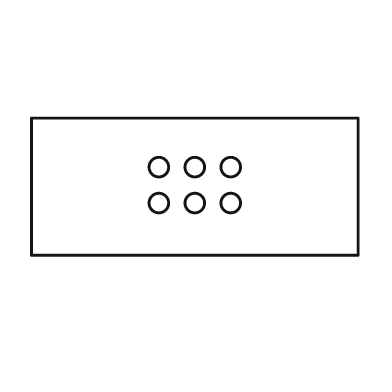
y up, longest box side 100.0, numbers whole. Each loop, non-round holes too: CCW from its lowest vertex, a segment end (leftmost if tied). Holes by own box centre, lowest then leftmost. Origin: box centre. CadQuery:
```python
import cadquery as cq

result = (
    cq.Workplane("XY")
    .moveTo(-50.0, -21.0)
    .lineTo(50.0, -21.0)
    .lineTo(50.0, 21.0)
    .lineTo(-50.0, 21.0)
    .close()
    .moveTo(-11.0, -5.0)
    .circle(3.0)
    .moveTo(0.0, -5.0)
    .circle(3.0)
    .moveTo(11.0, -5.0)
    .circle(3.0)
    .moveTo(-11.0, 6.0)
    .circle(3.0)
    .moveTo(0.0, 6.0)
    .circle(3.0)
    .moveTo(11.0, 6.0)
    .circle(3.0)
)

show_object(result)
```